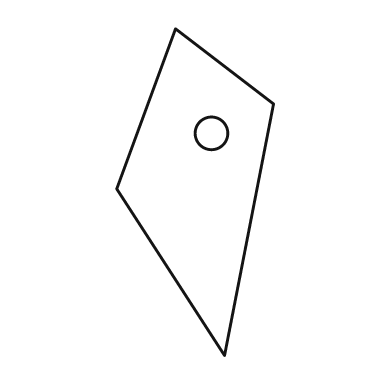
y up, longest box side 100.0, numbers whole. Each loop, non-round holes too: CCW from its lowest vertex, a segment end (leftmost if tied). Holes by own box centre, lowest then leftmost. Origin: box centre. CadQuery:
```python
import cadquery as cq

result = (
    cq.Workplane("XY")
    .moveTo(9.0, -50.0)
    .lineTo(24.0, 27.0)
    .lineTo(-6.0, 50.0)
    .lineTo(-24.0, 1.0)
    .close()
    .moveTo(5.0, 18.0)
    .circle(5.0)
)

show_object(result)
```